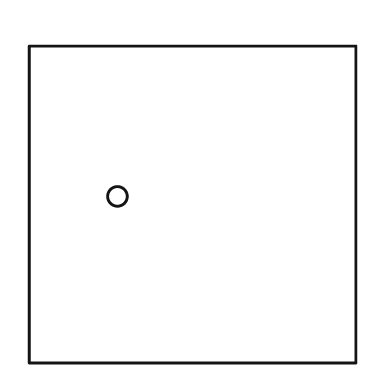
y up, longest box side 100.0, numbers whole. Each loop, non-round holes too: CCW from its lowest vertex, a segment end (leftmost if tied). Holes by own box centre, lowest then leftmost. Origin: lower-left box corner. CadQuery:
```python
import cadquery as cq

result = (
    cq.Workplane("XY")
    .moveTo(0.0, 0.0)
    .lineTo(100.0, 0.0)
    .lineTo(100.0, 97.0)
    .lineTo(0.0, 97.0)
    .close()
    .moveTo(27.0, 51.0)
    .circle(3.0)
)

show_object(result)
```